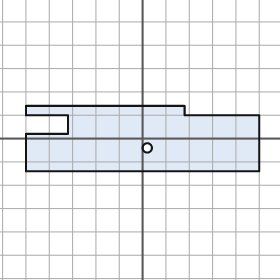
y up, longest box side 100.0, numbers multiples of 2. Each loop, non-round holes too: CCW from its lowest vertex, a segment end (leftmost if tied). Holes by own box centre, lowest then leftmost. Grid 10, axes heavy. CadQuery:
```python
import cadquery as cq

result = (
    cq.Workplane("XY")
    .moveTo(-50.0, -14.0)
    .lineTo(50.0, -14.0)
    .lineTo(50.0, 10.0)
    .lineTo(18.0, 10.0)
    .lineTo(18.0, 14.0)
    .lineTo(-50.0, 14.0)
    .lineTo(-50.0, 10.0)
    .lineTo(-32.0, 10.0)
    .lineTo(-32.0, 2.0)
    .lineTo(-50.0, 2.0)
    .close()
    .moveTo(2.0, -4.0)
    .circle(2.0)
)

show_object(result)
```